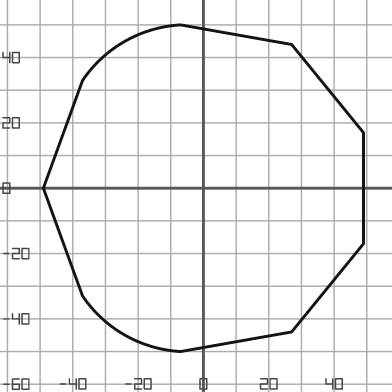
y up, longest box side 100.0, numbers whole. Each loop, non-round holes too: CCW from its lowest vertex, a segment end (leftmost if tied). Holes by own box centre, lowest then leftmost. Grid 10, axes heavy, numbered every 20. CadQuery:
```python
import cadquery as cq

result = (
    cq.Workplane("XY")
    .moveTo(-7.0, -50.0)
    .lineTo(27.0, -44.0)
    .lineTo(49.0, -17.0)
    .lineTo(49.0, 17.0)
    .lineTo(27.0, 44.0)
    .lineTo(-7.0, 50.0)
    .threePointArc((-24.0, 45.0), (-37.0, 33.0))
    .lineTo(-49.0, 0.0)
    .lineTo(-37.0, -33.0)
    .threePointArc((-24.0, -45.0), (-7.0, -50.0))
    .close()
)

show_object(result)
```